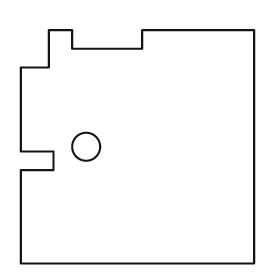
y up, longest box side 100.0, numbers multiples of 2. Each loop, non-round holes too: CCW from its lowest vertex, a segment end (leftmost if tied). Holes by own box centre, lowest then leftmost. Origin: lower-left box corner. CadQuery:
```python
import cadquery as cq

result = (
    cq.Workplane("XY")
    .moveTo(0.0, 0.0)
    .lineTo(100.0, 0.0)
    .lineTo(100.0, 100.0)
    .lineTo(52.0, 100.0)
    .lineTo(52.0, 92.0)
    .lineTo(22.0, 92.0)
    .lineTo(22.0, 100.0)
    .lineTo(12.0, 100.0)
    .lineTo(12.0, 84.0)
    .lineTo(0.0, 84.0)
    .lineTo(0.0, 48.0)
    .lineTo(14.0, 48.0)
    .lineTo(14.0, 40.0)
    .lineTo(0.0, 40.0)
    .close()
    .moveTo(28.0, 50.0)
    .circle(6.0)
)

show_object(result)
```